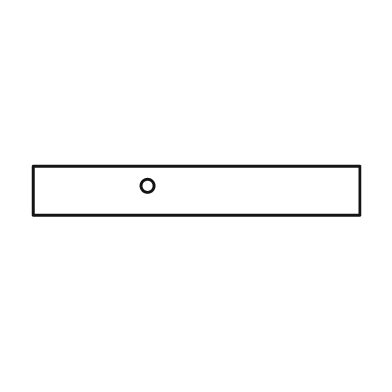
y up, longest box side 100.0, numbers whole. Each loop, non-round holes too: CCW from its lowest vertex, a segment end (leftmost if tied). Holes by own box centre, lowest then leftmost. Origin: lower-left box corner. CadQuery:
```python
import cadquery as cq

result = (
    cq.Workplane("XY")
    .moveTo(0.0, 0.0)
    .lineTo(100.0, 0.0)
    .lineTo(100.0, 15.0)
    .lineTo(0.0, 15.0)
    .close()
    .moveTo(35.0, 9.0)
    .circle(2.0)
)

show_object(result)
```